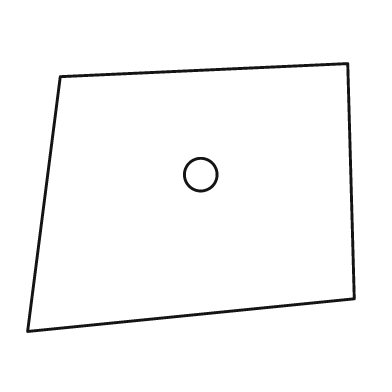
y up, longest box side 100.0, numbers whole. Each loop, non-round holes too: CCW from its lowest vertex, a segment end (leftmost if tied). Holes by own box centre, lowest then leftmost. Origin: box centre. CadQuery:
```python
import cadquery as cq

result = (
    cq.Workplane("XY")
    .moveTo(-50.0, -41.0)
    .lineTo(50.0, -31.0)
    .lineTo(48.0, 41.0)
    .lineTo(-40.0, 37.0)
    .close()
    .moveTo(3.0, 7.0)
    .circle(5.0)
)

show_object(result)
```